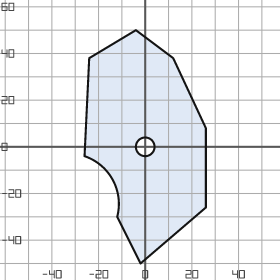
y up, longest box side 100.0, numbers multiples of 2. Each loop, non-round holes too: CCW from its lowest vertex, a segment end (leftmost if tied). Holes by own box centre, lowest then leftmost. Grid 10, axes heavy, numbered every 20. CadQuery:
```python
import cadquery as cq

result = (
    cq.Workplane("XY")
    .moveTo(-2.0, -50.0)
    .lineTo(26.0, -26.0)
    .lineTo(26.0, 8.0)
    .lineTo(12.0, 38.0)
    .lineTo(-4.0, 50.0)
    .lineTo(-24.0, 38.0)
    .lineTo(-26.0, -4.0)
    .threePointArc((-14.0, -14.0), (-12.0, -30.0))
    .close()
    .moveTo(0.0, 0.0)
    .circle(4.0)
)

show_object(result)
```